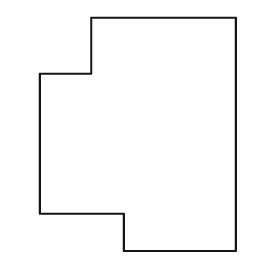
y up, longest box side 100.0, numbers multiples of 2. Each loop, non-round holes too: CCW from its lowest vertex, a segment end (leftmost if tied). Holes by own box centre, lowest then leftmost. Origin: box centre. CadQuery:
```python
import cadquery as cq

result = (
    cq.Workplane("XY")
    .moveTo(-6.0, -50.0)
    .lineTo(42.0, -50.0)
    .lineTo(42.0, 50.0)
    .lineTo(-20.0, 50.0)
    .lineTo(-20.0, 26.0)
    .lineTo(-42.0, 26.0)
    .lineTo(-42.0, -34.0)
    .lineTo(-6.0, -34.0)
    .close()
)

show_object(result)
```